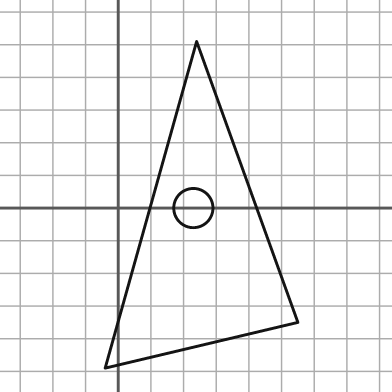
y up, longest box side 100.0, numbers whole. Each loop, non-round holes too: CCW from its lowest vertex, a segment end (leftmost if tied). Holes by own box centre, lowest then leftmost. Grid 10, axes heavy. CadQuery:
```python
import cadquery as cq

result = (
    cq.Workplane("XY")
    .moveTo(-4.0, -49.0)
    .lineTo(55.0, -35.0)
    .lineTo(24.0, 51.0)
    .close()
    .moveTo(23.0, 0.0)
    .circle(6.0)
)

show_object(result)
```